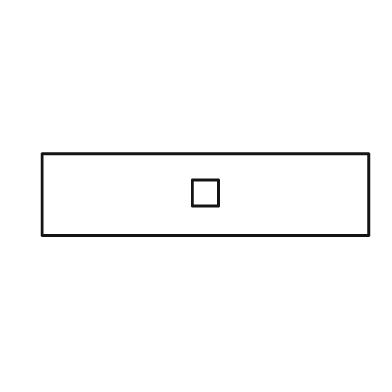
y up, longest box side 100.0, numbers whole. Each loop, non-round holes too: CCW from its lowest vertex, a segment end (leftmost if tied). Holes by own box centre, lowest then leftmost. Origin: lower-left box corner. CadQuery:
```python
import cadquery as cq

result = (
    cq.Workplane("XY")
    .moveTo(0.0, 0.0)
    .lineTo(100.0, 0.0)
    .lineTo(100.0, 25.0)
    .lineTo(0.0, 25.0)
    .close()
    .moveTo(46.0, 9.0)
    .lineTo(54.0, 9.0)
    .lineTo(54.0, 17.0)
    .lineTo(46.0, 17.0)
    .close()
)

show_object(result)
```